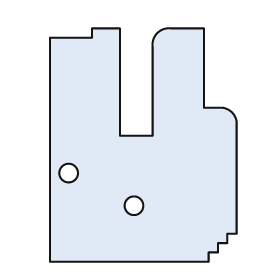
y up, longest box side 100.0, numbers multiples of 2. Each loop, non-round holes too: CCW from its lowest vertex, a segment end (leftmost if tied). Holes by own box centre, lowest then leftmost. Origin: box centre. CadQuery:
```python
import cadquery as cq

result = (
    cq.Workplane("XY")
    .moveTo(-40.0, -50.0)
    .lineTo(28.0, -50.0)
    .lineTo(28.0, -46.0)
    .lineTo(32.0, -46.0)
    .lineTo(32.0, -42.0)
    .lineTo(36.0, -42.0)
    .lineTo(36.0, -38.0)
    .lineTo(40.0, -38.0)
    .lineTo(40.0, 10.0)
    .threePointArc((38.0, 14.0), (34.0, 16.0))
    .lineTo(26.0, 16.0)
    .lineTo(26.0, 50.0)
    .lineTo(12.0, 50.0)
    .threePointArc((6.0, 48.0), (4.0, 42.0))
    .lineTo(4.0, 4.0)
    .lineTo(-10.0, 4.0)
    .lineTo(-10.0, 50.0)
    .lineTo(-22.0, 50.0)
    .lineTo(-22.0, 46.0)
    .lineTo(-40.0, 46.0)
    .close()
    .moveTo(-4.0, -26.0)
    .circle(4.0)
    .moveTo(-32.0, -12.0)
    .circle(4.0)
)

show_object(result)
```